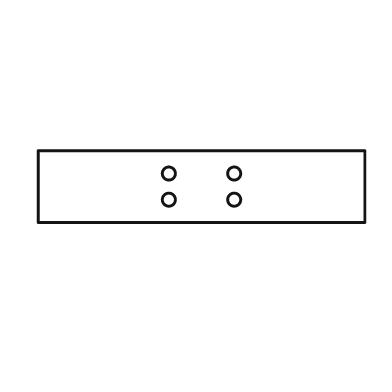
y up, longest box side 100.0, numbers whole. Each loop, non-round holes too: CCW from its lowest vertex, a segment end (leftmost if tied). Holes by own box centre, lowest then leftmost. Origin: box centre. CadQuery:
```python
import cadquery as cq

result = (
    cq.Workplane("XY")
    .moveTo(-50.0, -11.0)
    .lineTo(50.0, -11.0)
    .lineTo(50.0, 11.0)
    .lineTo(-50.0, 11.0)
    .close()
    .moveTo(-10.0, -4.0)
    .circle(2.0)
    .moveTo(10.0, -4.0)
    .circle(2.0)
    .moveTo(-10.0, 4.0)
    .circle(2.0)
    .moveTo(10.0, 4.0)
    .circle(2.0)
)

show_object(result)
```